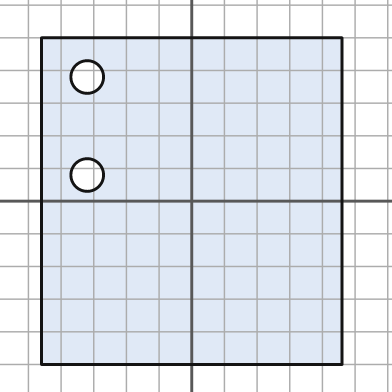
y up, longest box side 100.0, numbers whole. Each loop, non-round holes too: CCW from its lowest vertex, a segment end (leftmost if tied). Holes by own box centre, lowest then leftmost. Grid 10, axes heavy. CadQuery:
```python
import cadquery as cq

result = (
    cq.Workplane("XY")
    .moveTo(-46.0, -50.0)
    .lineTo(46.0, -50.0)
    .lineTo(46.0, 50.0)
    .lineTo(-46.0, 50.0)
    .close()
    .moveTo(-32.0, 8.0)
    .circle(5.0)
    .moveTo(-32.0, 38.0)
    .circle(5.0)
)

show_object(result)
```